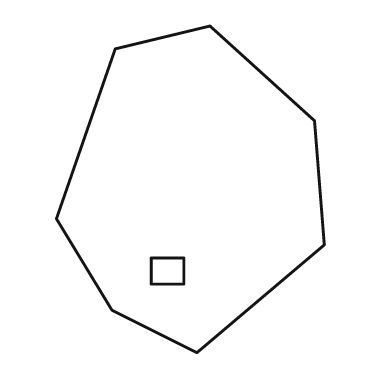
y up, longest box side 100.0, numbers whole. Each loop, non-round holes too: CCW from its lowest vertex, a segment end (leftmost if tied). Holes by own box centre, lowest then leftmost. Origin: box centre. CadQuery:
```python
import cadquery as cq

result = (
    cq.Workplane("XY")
    .moveTo(2.0, -50.0)
    .lineTo(41.0, -17.0)
    .lineTo(38.0, 21.0)
    .lineTo(6.0, 50.0)
    .lineTo(-23.0, 43.0)
    .lineTo(-41.0, -9.0)
    .lineTo(-24.0, -37.0)
    .close()
    .moveTo(-12.0, -29.0)
    .lineTo(-2.0, -29.0)
    .lineTo(-2.0, -21.0)
    .lineTo(-12.0, -21.0)
    .close()
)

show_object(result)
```